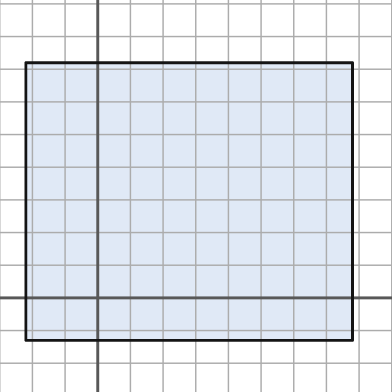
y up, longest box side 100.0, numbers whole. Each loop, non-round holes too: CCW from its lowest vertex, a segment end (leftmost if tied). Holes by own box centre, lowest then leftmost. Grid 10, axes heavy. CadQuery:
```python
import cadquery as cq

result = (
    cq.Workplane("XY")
    .moveTo(-22.0, -13.0)
    .lineTo(78.0, -13.0)
    .lineTo(78.0, 72.0)
    .lineTo(-22.0, 72.0)
    .close()
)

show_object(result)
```